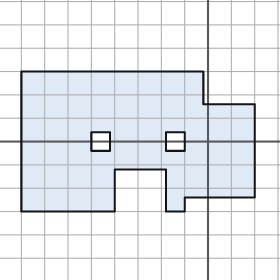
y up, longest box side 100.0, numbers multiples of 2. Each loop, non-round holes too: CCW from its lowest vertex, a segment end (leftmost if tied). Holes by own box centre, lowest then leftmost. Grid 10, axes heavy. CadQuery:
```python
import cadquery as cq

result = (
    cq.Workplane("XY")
    .moveTo(-80.0, -30.0)
    .lineTo(-40.0, -30.0)
    .lineTo(-40.0, -12.0)
    .lineTo(-18.0, -12.0)
    .lineTo(-18.0, -30.0)
    .lineTo(-10.0, -30.0)
    .lineTo(-10.0, -24.0)
    .lineTo(20.0, -24.0)
    .lineTo(20.0, 16.0)
    .lineTo(-2.0, 16.0)
    .lineTo(-2.0, 30.0)
    .lineTo(-80.0, 30.0)
    .close()
    .moveTo(-50.0, -4.0)
    .lineTo(-42.0, -4.0)
    .lineTo(-42.0, 4.0)
    .lineTo(-50.0, 4.0)
    .close()
    .moveTo(-18.0, -4.0)
    .lineTo(-10.0, -4.0)
    .lineTo(-10.0, 4.0)
    .lineTo(-18.0, 4.0)
    .close()
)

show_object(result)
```